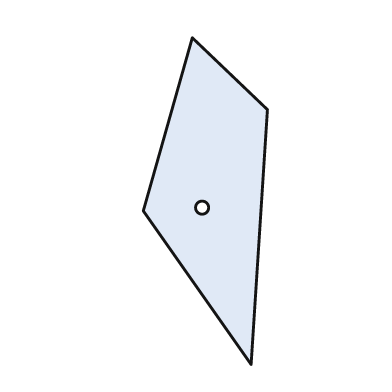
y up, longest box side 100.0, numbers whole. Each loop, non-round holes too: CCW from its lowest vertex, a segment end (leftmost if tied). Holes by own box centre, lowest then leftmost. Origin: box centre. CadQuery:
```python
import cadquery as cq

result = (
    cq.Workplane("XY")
    .moveTo(14.0, -50.0)
    .lineTo(19.0, 28.0)
    .lineTo(-4.0, 50.0)
    .lineTo(-19.0, -3.0)
    .close()
    .moveTo(-1.0, -2.0)
    .circle(2.0)
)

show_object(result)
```